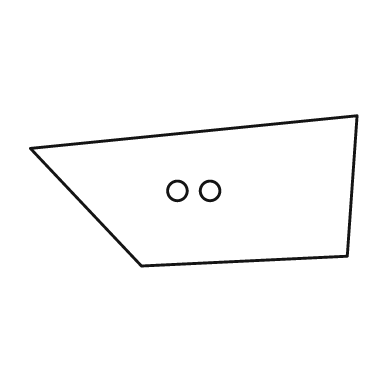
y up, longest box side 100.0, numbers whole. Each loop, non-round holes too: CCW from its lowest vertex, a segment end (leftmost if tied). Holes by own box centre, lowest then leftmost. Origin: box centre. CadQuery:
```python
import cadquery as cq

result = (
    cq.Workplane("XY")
    .moveTo(-16.0, -23.0)
    .lineTo(47.0, -20.0)
    .lineTo(50.0, 23.0)
    .lineTo(-50.0, 13.0)
    .close()
    .moveTo(-5.0, 0.0)
    .circle(3.0)
    .moveTo(5.0, 0.0)
    .circle(3.0)
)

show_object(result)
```